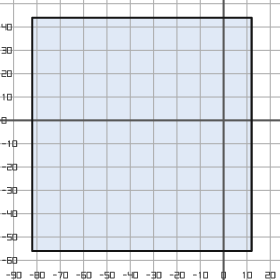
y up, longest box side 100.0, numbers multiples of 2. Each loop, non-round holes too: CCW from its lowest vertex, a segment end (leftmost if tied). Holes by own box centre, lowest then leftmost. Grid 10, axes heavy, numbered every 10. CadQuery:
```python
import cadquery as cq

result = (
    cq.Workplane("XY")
    .moveTo(-82.0, -56.0)
    .lineTo(12.0, -56.0)
    .lineTo(12.0, 44.0)
    .lineTo(-82.0, 44.0)
    .close()
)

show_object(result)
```